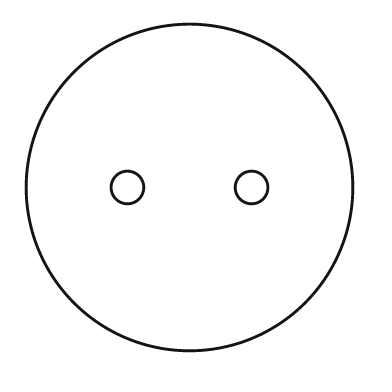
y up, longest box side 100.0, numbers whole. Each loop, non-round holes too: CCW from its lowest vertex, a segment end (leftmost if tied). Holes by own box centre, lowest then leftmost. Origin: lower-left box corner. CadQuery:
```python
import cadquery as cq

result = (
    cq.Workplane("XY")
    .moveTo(50.0, 50.0)
    .circle(50.0)
    .moveTo(31.0, 50.0)
    .circle(5.0)
    .moveTo(69.0, 50.0)
    .circle(5.0)
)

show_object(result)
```